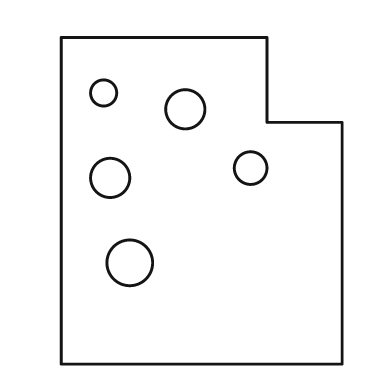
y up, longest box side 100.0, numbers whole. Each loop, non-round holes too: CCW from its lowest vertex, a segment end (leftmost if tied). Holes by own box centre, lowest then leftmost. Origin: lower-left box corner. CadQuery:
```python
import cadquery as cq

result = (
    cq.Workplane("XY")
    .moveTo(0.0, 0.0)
    .lineTo(86.0, 0.0)
    .lineTo(86.0, 74.0)
    .lineTo(63.0, 74.0)
    .lineTo(63.0, 100.0)
    .lineTo(0.0, 100.0)
    .close()
    .moveTo(21.0, 31.0)
    .circle(7.0)
    .moveTo(15.0, 57.0)
    .circle(6.0)
    .moveTo(58.0, 60.0)
    .circle(5.0)
    .moveTo(38.0, 78.0)
    .circle(6.0)
    .moveTo(13.0, 83.0)
    .circle(4.0)
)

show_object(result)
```